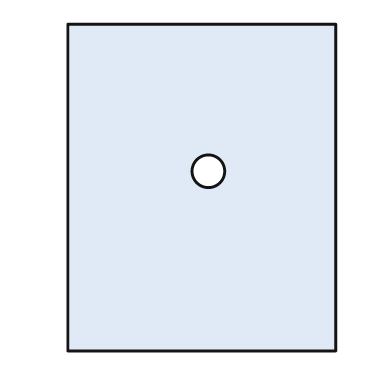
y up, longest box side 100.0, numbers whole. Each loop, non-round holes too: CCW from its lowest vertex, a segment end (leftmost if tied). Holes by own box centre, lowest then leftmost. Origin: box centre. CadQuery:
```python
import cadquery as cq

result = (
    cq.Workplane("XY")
    .moveTo(-41.0, -50.0)
    .lineTo(41.0, -50.0)
    .lineTo(41.0, 50.0)
    .lineTo(-41.0, 50.0)
    .close()
    .moveTo(2.0, 5.0)
    .circle(5.0)
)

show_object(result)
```